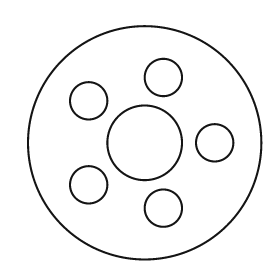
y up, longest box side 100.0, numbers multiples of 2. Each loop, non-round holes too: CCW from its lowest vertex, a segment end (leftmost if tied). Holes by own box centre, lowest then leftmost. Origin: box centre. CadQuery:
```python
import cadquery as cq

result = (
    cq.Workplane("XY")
    .moveTo(0.0, 0.0)
    .circle(50.0)
    .moveTo(8.0, -28.0)
    .circle(8.0)
    .moveTo(-24.0, -18.0)
    .circle(8.0)
    .moveTo(0.0, 0.0)
    .circle(16.0)
    .moveTo(30.0, 0.0)
    .circle(8.0)
    .moveTo(-24.0, 18.0)
    .circle(8.0)
    .moveTo(8.0, 28.0)
    .circle(8.0)
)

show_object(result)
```